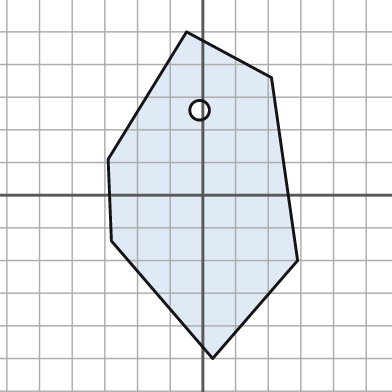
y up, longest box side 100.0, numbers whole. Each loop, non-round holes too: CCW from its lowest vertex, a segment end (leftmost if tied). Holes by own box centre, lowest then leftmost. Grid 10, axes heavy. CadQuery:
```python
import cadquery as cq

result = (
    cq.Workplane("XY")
    .moveTo(3.0, -50.0)
    .lineTo(29.0, -20.0)
    .lineTo(21.0, 36.0)
    .lineTo(-5.0, 50.0)
    .lineTo(-29.0, 11.0)
    .lineTo(-28.0, -14.0)
    .close()
    .moveTo(-1.0, 26.0)
    .circle(3.0)
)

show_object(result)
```